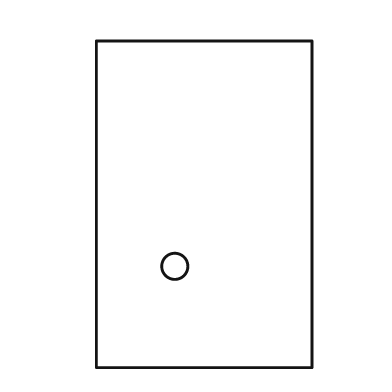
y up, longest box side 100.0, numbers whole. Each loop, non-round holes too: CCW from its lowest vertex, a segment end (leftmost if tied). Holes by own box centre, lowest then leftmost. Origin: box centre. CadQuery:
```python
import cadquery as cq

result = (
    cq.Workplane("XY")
    .moveTo(-33.0, -50.0)
    .lineTo(33.0, -50.0)
    .lineTo(33.0, 50.0)
    .lineTo(-33.0, 50.0)
    .close()
    .moveTo(-9.0, -19.0)
    .circle(4.0)
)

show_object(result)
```